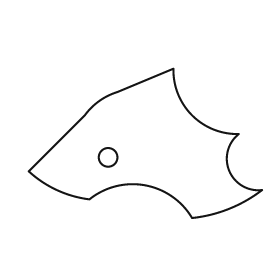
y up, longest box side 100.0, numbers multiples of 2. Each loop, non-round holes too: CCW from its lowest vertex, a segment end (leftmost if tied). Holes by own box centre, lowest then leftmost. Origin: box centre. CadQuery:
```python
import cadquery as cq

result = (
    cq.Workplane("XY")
    .moveTo(20.0, -32.0)
    .threePointArc((36.0, -28.0), (50.0, -20.0))
    .threePointArc((36.0, -12.0), (40.0, 4.0))
    .threePointArc((20.0, 12.0), (12.0, 32.0))
    .lineTo(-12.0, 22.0)
    .threePointArc((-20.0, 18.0), (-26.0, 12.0))
    .lineTo(-50.0, -12.0)
    .threePointArc((-38.0, -20.0), (-24.0, -24.0))
    .threePointArc((0.0, -18.0), (20.0, -32.0))
    .close()
    .moveTo(-16.0, -6.0)
    .circle(4.0)
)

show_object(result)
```